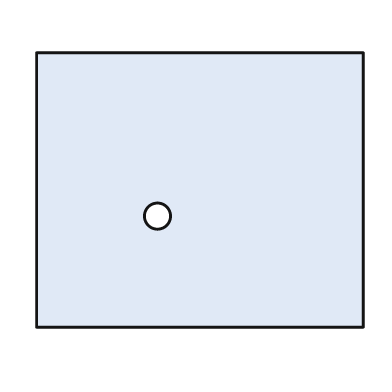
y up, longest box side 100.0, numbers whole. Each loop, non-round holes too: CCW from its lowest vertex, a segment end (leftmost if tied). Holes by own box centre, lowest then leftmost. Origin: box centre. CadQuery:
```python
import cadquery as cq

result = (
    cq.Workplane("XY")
    .moveTo(-50.0, -42.0)
    .lineTo(50.0, -42.0)
    .lineTo(50.0, 42.0)
    .lineTo(-50.0, 42.0)
    .close()
    .moveTo(-13.0, -8.0)
    .circle(4.0)
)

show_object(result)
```